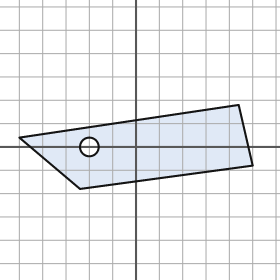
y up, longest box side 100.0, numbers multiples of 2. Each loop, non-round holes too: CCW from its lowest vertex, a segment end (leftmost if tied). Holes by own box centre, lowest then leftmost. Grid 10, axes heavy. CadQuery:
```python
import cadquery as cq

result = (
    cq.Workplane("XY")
    .moveTo(-24.0, -18.0)
    .lineTo(50.0, -8.0)
    .lineTo(44.0, 18.0)
    .lineTo(-50.0, 4.0)
    .close()
    .moveTo(-20.0, 0.0)
    .circle(4.0)
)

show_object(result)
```